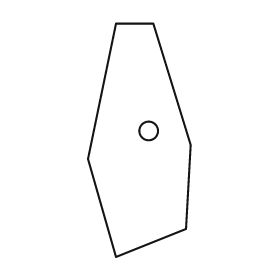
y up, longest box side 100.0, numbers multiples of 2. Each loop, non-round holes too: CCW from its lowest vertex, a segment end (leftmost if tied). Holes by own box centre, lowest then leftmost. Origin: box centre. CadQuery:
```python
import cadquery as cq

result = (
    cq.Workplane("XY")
    .moveTo(-10.0, -50.0)
    .lineTo(20.0, -38.0)
    .lineTo(22.0, -2.0)
    .lineTo(6.0, 50.0)
    .lineTo(-10.0, 50.0)
    .lineTo(-22.0, -8.0)
    .close()
    .moveTo(4.0, 4.0)
    .circle(4.0)
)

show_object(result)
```